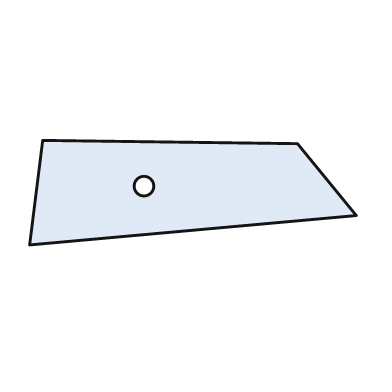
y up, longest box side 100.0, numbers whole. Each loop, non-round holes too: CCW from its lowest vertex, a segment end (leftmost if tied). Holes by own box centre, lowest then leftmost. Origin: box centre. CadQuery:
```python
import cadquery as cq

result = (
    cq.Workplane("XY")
    .moveTo(-50.0, -16.0)
    .lineTo(50.0, -7.0)
    .lineTo(32.0, 15.0)
    .lineTo(-46.0, 16.0)
    .close()
    .moveTo(-15.0, 2.0)
    .circle(3.0)
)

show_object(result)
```